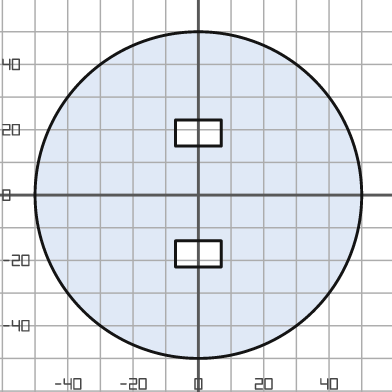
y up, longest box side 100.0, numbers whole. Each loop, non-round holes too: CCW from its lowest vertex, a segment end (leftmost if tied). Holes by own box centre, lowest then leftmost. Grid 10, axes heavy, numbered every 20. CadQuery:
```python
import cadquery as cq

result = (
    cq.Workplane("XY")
    .moveTo(0.0, 0.0)
    .circle(50.0)
    .moveTo(-7.0, -22.0)
    .lineTo(7.0, -22.0)
    .lineTo(7.0, -14.0)
    .lineTo(-7.0, -14.0)
    .close()
    .moveTo(-7.0, 15.0)
    .lineTo(7.0, 15.0)
    .lineTo(7.0, 23.0)
    .lineTo(-7.0, 23.0)
    .close()
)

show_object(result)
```